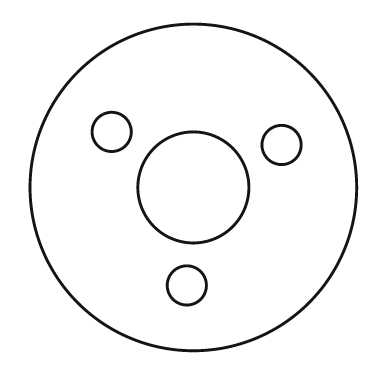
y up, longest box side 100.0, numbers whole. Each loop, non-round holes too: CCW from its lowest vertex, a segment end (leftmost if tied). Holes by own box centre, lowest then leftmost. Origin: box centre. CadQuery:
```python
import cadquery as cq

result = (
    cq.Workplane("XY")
    .moveTo(0.0, 0.0)
    .circle(50.0)
    .moveTo(-2.0, -30.0)
    .circle(6.0)
    .moveTo(0.0, 0.0)
    .circle(17.0)
    .moveTo(27.0, 13.0)
    .circle(6.0)
    .moveTo(-25.0, 17.0)
    .circle(6.0)
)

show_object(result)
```